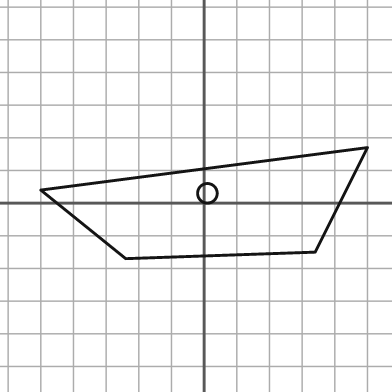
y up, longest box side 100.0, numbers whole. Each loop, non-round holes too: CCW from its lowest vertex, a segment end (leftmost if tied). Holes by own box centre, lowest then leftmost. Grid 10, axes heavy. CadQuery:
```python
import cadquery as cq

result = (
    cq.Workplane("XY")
    .moveTo(-24.0, -17.0)
    .lineTo(34.0, -15.0)
    .lineTo(50.0, 17.0)
    .lineTo(-50.0, 4.0)
    .close()
    .moveTo(1.0, 3.0)
    .circle(3.0)
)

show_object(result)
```